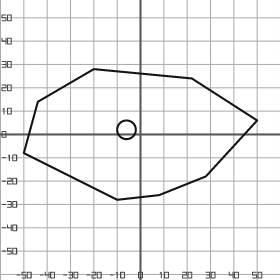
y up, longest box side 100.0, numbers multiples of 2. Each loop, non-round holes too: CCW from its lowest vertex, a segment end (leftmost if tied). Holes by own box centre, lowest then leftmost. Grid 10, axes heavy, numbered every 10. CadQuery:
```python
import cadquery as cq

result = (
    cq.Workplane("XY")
    .moveTo(-10.0, -28.0)
    .lineTo(8.0, -26.0)
    .lineTo(28.0, -18.0)
    .lineTo(50.0, 6.0)
    .lineTo(22.0, 24.0)
    .lineTo(-20.0, 28.0)
    .lineTo(-44.0, 14.0)
    .lineTo(-50.0, -8.0)
    .close()
    .moveTo(-6.0, 2.0)
    .circle(4.0)
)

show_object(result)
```